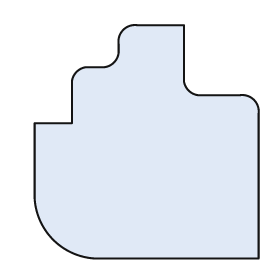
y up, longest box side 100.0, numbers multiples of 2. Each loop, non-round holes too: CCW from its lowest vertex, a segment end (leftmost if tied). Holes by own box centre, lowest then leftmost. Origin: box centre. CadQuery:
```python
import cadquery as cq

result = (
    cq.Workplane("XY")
    .moveTo(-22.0, -50.0)
    .lineTo(48.0, -50.0)
    .lineTo(48.0, 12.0)
    .threePointArc((46.0, 18.0), (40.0, 20.0))
    .lineTo(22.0, 20.0)
    .threePointArc((18.0, 22.0), (16.0, 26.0))
    .lineTo(16.0, 50.0)
    .lineTo(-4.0, 50.0)
    .threePointArc((-10.0, 48.0), (-12.0, 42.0))
    .lineTo(-12.0, 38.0)
    .threePointArc((-14.0, 34.0), (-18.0, 32.0))
    .lineTo(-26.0, 32.0)
    .threePointArc((-30.0, 30.0), (-32.0, 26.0))
    .lineTo(-32.0, 8.0)
    .lineTo(-48.0, 8.0)
    .lineTo(-48.0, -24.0)
    .threePointArc((-40.0, -42.0), (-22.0, -50.0))
    .close()
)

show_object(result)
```